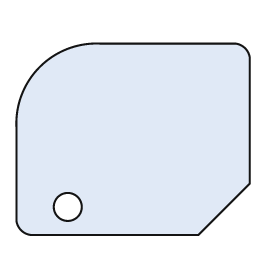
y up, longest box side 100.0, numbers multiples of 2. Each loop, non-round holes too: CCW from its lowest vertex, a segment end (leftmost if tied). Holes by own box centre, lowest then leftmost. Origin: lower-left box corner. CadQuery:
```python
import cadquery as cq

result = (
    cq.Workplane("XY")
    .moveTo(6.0, 0.0)
    .lineTo(78.0, 0.0)
    .lineTo(100.0, 22.0)
    .lineTo(100.0, 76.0)
    .threePointArc((98.0, 80.0), (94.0, 82.0))
    .lineTo(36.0, 82.0)
    .threePointArc((10.0, 72.0), (0.0, 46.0))
    .lineTo(0.0, 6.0)
    .threePointArc((2.0, 2.0), (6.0, 0.0))
    .close()
    .moveTo(22.0, 12.0)
    .circle(6.0)
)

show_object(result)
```